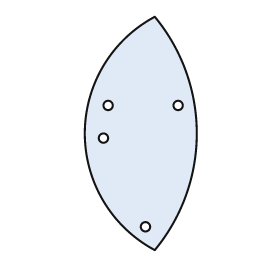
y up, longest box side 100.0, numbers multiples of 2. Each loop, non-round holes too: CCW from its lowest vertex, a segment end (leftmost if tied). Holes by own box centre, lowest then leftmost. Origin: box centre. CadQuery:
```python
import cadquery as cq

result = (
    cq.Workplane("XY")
    .moveTo(6.0, -50.0)
    .threePointArc((24.0, 0.0), (6.0, 50.0))
    .threePointArc((-24.0, 0.0), (6.0, -50.0))
    .close()
    .moveTo(2.0, -40.0)
    .circle(2.0)
    .moveTo(-16.0, -2.0)
    .circle(2.0)
    .moveTo(-14.0, 12.0)
    .circle(2.0)
    .moveTo(16.0, 12.0)
    .circle(2.0)
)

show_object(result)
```